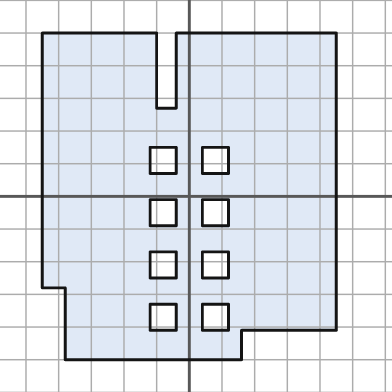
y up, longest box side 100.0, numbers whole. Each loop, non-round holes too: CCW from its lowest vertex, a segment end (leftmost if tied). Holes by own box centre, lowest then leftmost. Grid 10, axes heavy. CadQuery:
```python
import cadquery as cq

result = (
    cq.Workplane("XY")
    .moveTo(-38.0, -50.0)
    .lineTo(16.0, -50.0)
    .lineTo(16.0, -41.0)
    .lineTo(45.0, -41.0)
    .lineTo(45.0, 50.0)
    .lineTo(-4.0, 50.0)
    .lineTo(-4.0, 27.0)
    .lineTo(-10.0, 27.0)
    .lineTo(-10.0, 50.0)
    .lineTo(-45.0, 50.0)
    .lineTo(-45.0, -28.0)
    .lineTo(-38.0, -28.0)
    .close()
    .moveTo(-12.0, -41.0)
    .lineTo(-4.0, -41.0)
    .lineTo(-4.0, -33.0)
    .lineTo(-12.0, -33.0)
    .close()
    .moveTo(4.0, -41.0)
    .lineTo(12.0, -41.0)
    .lineTo(12.0, -33.0)
    .lineTo(4.0, -33.0)
    .close()
    .moveTo(-12.0, -25.0)
    .lineTo(-4.0, -25.0)
    .lineTo(-4.0, -17.0)
    .lineTo(-12.0, -17.0)
    .close()
    .moveTo(4.0, -25.0)
    .lineTo(12.0, -25.0)
    .lineTo(12.0, -17.0)
    .lineTo(4.0, -17.0)
    .close()
    .moveTo(-12.0, -9.0)
    .lineTo(-4.0, -9.0)
    .lineTo(-4.0, -1.0)
    .lineTo(-12.0, -1.0)
    .close()
    .moveTo(4.0, -9.0)
    .lineTo(12.0, -9.0)
    .lineTo(12.0, -1.0)
    .lineTo(4.0, -1.0)
    .close()
    .moveTo(-12.0, 7.0)
    .lineTo(-4.0, 7.0)
    .lineTo(-4.0, 15.0)
    .lineTo(-12.0, 15.0)
    .close()
    .moveTo(4.0, 7.0)
    .lineTo(12.0, 7.0)
    .lineTo(12.0, 15.0)
    .lineTo(4.0, 15.0)
    .close()
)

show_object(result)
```